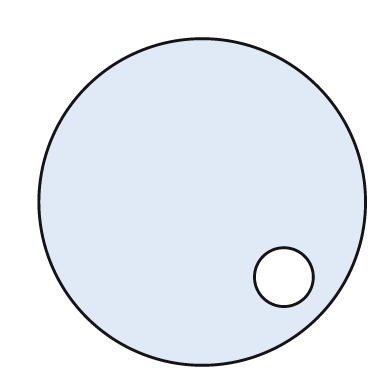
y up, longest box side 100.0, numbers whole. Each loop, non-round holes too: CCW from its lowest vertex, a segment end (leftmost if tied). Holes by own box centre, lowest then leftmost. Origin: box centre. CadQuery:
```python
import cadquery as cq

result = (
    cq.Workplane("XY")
    .moveTo(0.0, 0.0)
    .circle(50.0)
    .moveTo(25.0, -23.0)
    .circle(9.0)
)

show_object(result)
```